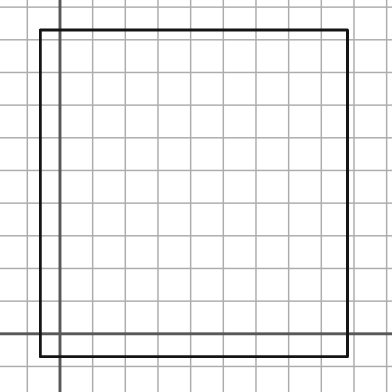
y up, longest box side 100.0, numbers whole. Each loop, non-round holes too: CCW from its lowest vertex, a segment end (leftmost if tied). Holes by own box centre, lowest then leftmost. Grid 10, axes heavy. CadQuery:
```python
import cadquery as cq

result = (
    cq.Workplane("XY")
    .moveTo(-6.0, -7.0)
    .lineTo(88.0, -7.0)
    .lineTo(88.0, 93.0)
    .lineTo(-6.0, 93.0)
    .close()
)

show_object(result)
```